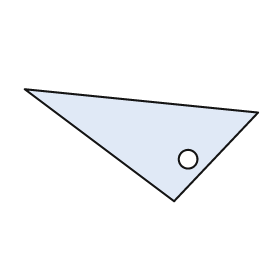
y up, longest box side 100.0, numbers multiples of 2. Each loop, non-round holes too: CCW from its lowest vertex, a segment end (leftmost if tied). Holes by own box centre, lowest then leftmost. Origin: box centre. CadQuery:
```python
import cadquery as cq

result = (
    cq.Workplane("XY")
    .moveTo(14.0, -24.0)
    .lineTo(50.0, 14.0)
    .lineTo(-50.0, 24.0)
    .close()
    .moveTo(20.0, -6.0)
    .circle(4.0)
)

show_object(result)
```